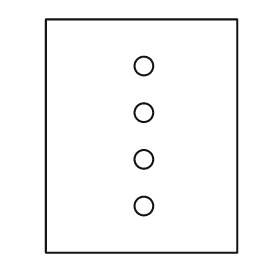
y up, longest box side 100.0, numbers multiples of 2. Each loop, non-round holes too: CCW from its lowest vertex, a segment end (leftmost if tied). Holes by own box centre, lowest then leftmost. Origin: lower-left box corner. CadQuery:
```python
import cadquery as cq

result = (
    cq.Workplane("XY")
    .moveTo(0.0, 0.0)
    .lineTo(82.0, 0.0)
    .lineTo(82.0, 100.0)
    .lineTo(0.0, 100.0)
    .close()
    .moveTo(42.0, 20.0)
    .circle(4.0)
    .moveTo(42.0, 40.0)
    .circle(4.0)
    .moveTo(42.0, 60.0)
    .circle(4.0)
    .moveTo(42.0, 80.0)
    .circle(4.0)
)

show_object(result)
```